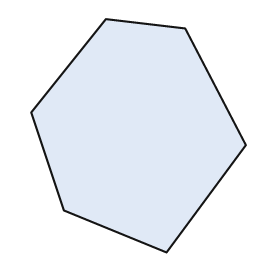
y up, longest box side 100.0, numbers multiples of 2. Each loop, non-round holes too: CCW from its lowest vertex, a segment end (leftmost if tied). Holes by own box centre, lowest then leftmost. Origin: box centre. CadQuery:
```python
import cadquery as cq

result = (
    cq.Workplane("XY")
    .moveTo(12.0, -50.0)
    .lineTo(46.0, -4.0)
    .lineTo(20.0, 46.0)
    .lineTo(-14.0, 50.0)
    .lineTo(-46.0, 10.0)
    .lineTo(-32.0, -32.0)
    .close()
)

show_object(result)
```